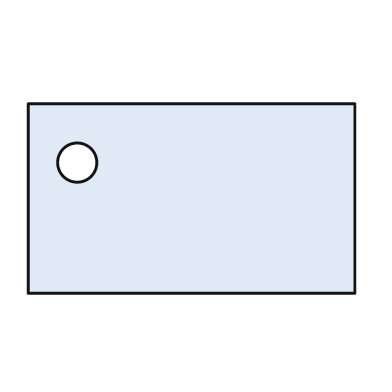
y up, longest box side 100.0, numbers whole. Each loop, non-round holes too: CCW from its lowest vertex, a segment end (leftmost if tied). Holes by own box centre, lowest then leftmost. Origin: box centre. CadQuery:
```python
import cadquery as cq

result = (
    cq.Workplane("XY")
    .moveTo(-50.0, -29.0)
    .lineTo(50.0, -29.0)
    .lineTo(50.0, 29.0)
    .lineTo(-50.0, 29.0)
    .close()
    .moveTo(-35.0, 11.0)
    .circle(6.0)
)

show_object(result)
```